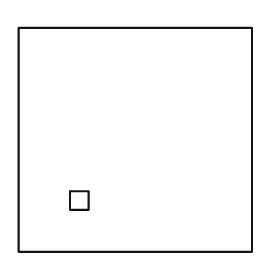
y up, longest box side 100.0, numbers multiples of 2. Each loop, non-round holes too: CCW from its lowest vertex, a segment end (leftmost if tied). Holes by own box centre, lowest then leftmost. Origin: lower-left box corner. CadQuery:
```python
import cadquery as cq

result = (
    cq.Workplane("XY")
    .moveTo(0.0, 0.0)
    .lineTo(100.0, 0.0)
    .lineTo(100.0, 96.0)
    .lineTo(0.0, 96.0)
    .close()
    .moveTo(22.0, 18.0)
    .lineTo(30.0, 18.0)
    .lineTo(30.0, 26.0)
    .lineTo(22.0, 26.0)
    .close()
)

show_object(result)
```